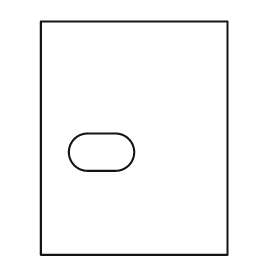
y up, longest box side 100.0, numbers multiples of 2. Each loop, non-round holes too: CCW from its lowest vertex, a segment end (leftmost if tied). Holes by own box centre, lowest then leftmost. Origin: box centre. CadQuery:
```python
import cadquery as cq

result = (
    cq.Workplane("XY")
    .moveTo(-40.0, -50.0)
    .lineTo(40.0, -50.0)
    .lineTo(40.0, 50.0)
    .lineTo(-40.0, 50.0)
    .close()
    .moveTo(-20.0, -14.0)
    .lineTo(-8.0, -14.0)
    .threePointArc((0.0, -6.0), (-8.0, 2.0))
    .lineTo(-20.0, 2.0)
    .threePointArc((-28.0, -6.0), (-20.0, -14.0))
    .close()
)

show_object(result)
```